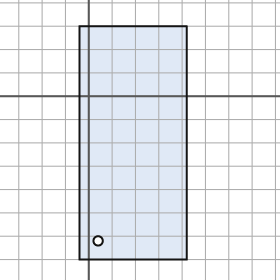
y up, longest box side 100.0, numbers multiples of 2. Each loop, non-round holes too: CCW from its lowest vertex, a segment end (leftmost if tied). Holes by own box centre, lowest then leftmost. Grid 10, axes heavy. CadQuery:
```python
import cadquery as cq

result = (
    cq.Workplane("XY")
    .moveTo(-4.0, -70.0)
    .lineTo(42.0, -70.0)
    .lineTo(42.0, 30.0)
    .lineTo(-4.0, 30.0)
    .close()
    .moveTo(4.0, -62.0)
    .circle(2.0)
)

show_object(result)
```